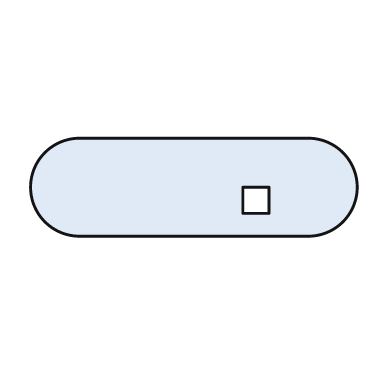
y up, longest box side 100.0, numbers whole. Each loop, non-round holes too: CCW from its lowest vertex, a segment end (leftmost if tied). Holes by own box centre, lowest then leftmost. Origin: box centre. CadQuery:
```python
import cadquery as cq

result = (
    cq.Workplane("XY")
    .moveTo(-35.0, -15.0)
    .lineTo(35.0, -15.0)
    .threePointArc((50.0, 0.0), (35.0, 15.0))
    .lineTo(-35.0, 15.0)
    .threePointArc((-50.0, 0.0), (-35.0, -15.0))
    .close()
    .moveTo(15.0, -8.0)
    .lineTo(23.0, -8.0)
    .lineTo(23.0, 0.0)
    .lineTo(15.0, 0.0)
    .close()
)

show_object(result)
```